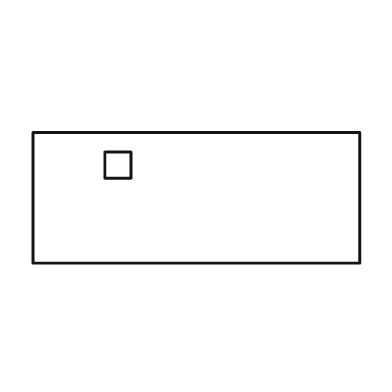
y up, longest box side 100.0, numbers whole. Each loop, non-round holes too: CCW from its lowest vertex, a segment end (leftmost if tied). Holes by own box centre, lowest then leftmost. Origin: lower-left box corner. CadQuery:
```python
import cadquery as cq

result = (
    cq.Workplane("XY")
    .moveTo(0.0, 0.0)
    .lineTo(100.0, 0.0)
    .lineTo(100.0, 40.0)
    .lineTo(0.0, 40.0)
    .close()
    .moveTo(22.0, 26.0)
    .lineTo(30.0, 26.0)
    .lineTo(30.0, 34.0)
    .lineTo(22.0, 34.0)
    .close()
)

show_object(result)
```